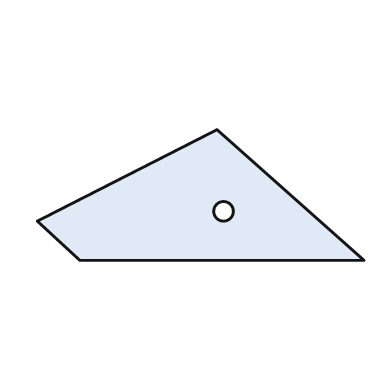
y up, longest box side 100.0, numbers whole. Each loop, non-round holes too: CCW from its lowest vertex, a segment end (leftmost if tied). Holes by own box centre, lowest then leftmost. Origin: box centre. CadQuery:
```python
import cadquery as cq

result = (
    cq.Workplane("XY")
    .moveTo(-37.0, -20.0)
    .lineTo(50.0, -20.0)
    .lineTo(5.0, 20.0)
    .lineTo(-50.0, -8.0)
    .close()
    .moveTo(7.0, -5.0)
    .circle(3.0)
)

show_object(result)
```